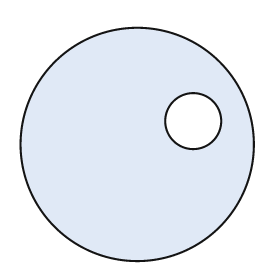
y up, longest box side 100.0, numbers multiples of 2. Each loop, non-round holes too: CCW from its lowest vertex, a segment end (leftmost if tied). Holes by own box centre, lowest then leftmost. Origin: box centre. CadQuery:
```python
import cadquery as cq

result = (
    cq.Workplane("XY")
    .moveTo(0.0, 0.0)
    .circle(50.0)
    .moveTo(24.0, 10.0)
    .circle(12.0)
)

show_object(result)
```